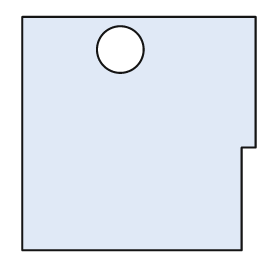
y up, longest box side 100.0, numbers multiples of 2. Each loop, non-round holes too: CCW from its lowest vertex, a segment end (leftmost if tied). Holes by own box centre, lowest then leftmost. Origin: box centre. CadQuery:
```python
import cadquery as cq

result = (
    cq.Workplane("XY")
    .moveTo(-50.0, -50.0)
    .lineTo(44.0, -50.0)
    .lineTo(44.0, -6.0)
    .lineTo(50.0, -6.0)
    .lineTo(50.0, 50.0)
    .lineTo(-50.0, 50.0)
    .close()
    .moveTo(-8.0, 36.0)
    .circle(10.0)
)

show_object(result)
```